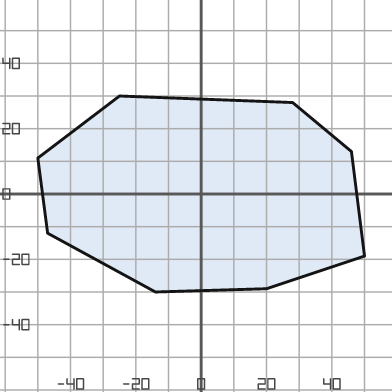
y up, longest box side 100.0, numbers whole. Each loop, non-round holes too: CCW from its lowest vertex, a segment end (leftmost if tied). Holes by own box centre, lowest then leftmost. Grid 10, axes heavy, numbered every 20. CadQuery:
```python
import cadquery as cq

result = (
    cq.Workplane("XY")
    .moveTo(-14.0, -30.0)
    .lineTo(20.0, -29.0)
    .lineTo(50.0, -19.0)
    .lineTo(46.0, 13.0)
    .lineTo(28.0, 28.0)
    .lineTo(-25.0, 30.0)
    .lineTo(-50.0, 11.0)
    .lineTo(-47.0, -12.0)
    .close()
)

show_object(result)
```